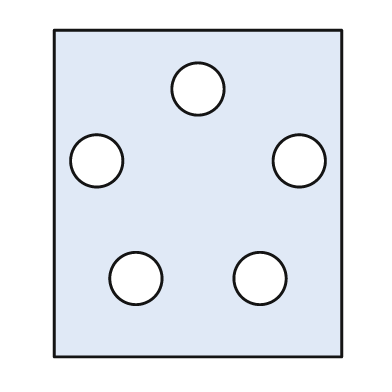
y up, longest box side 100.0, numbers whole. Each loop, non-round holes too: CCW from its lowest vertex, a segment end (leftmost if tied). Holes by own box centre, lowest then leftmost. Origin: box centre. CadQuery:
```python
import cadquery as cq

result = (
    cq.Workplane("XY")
    .moveTo(-44.0, -50.0)
    .lineTo(44.0, -50.0)
    .lineTo(44.0, 50.0)
    .lineTo(-44.0, 50.0)
    .close()
    .moveTo(-19.0, -26.0)
    .circle(8.0)
    .moveTo(19.0, -26.0)
    .circle(8.0)
    .moveTo(-31.0, 10.0)
    .circle(8.0)
    .moveTo(31.0, 10.0)
    .circle(8.0)
    .moveTo(0.0, 32.0)
    .circle(8.0)
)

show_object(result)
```